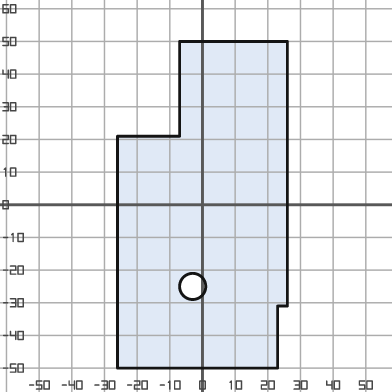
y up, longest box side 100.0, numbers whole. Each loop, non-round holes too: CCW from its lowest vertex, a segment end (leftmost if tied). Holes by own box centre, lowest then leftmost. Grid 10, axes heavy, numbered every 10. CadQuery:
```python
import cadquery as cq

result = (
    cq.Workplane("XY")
    .moveTo(-26.0, -50.0)
    .lineTo(23.0, -50.0)
    .lineTo(23.0, -31.0)
    .lineTo(26.0, -31.0)
    .lineTo(26.0, 50.0)
    .lineTo(-7.0, 50.0)
    .lineTo(-7.0, 21.0)
    .lineTo(-26.0, 21.0)
    .close()
    .moveTo(-3.0, -25.0)
    .circle(4.0)
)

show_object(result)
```